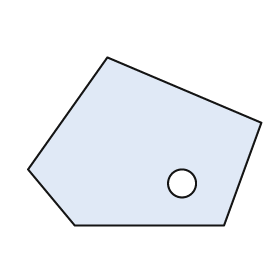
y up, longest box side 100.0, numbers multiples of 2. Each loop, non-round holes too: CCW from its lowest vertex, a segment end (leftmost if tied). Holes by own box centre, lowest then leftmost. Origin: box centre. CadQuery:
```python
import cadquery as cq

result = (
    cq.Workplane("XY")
    .moveTo(-30.0, -36.0)
    .lineTo(34.0, -36.0)
    .lineTo(50.0, 8.0)
    .lineTo(-16.0, 36.0)
    .lineTo(-50.0, -12.0)
    .close()
    .moveTo(16.0, -18.0)
    .circle(6.0)
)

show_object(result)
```